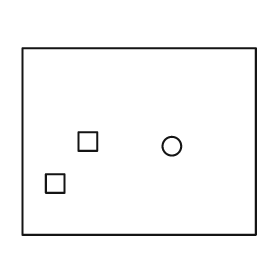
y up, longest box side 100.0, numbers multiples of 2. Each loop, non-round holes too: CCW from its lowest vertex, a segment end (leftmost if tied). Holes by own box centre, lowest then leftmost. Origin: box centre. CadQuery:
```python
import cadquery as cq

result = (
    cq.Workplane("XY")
    .moveTo(-50.0, -40.0)
    .lineTo(50.0, -40.0)
    .lineTo(50.0, 40.0)
    .lineTo(-50.0, 40.0)
    .close()
    .moveTo(-40.0, -22.0)
    .lineTo(-32.0, -22.0)
    .lineTo(-32.0, -14.0)
    .lineTo(-40.0, -14.0)
    .close()
    .moveTo(14.0, -2.0)
    .circle(4.0)
    .moveTo(-26.0, -4.0)
    .lineTo(-18.0, -4.0)
    .lineTo(-18.0, 4.0)
    .lineTo(-26.0, 4.0)
    .close()
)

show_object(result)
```